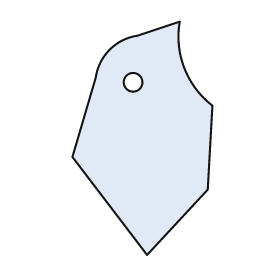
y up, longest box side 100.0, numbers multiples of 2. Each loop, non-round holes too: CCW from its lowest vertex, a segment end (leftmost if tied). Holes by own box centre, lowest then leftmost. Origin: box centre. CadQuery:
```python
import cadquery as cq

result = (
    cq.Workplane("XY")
    .moveTo(2.0, -50.0)
    .lineTo(28.0, -22.0)
    .lineTo(30.0, 14.0)
    .threePointArc((18.0, 30.0), (16.0, 50.0))
    .lineTo(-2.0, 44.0)
    .threePointArc((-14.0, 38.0), (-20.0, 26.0))
    .lineTo(-30.0, -8.0)
    .close()
    .moveTo(-4.0, 24.0)
    .circle(4.0)
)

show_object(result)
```